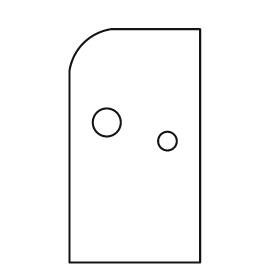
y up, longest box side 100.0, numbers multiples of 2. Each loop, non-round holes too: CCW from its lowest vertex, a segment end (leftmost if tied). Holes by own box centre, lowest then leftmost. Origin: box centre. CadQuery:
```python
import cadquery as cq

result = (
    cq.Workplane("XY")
    .moveTo(-28.0, -50.0)
    .lineTo(28.0, -50.0)
    .lineTo(28.0, 50.0)
    .lineTo(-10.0, 50.0)
    .threePointArc((-22.0, 44.0), (-28.0, 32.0))
    .close()
    .moveTo(14.0, 2.0)
    .circle(4.0)
    .moveTo(-12.0, 10.0)
    .circle(6.0)
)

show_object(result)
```